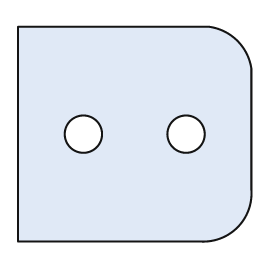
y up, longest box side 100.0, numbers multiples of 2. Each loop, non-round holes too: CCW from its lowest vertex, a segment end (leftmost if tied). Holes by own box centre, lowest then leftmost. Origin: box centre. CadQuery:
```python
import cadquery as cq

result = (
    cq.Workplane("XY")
    .moveTo(-50.0, -46.0)
    .lineTo(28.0, -46.0)
    .threePointArc((44.0, -40.0), (50.0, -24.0))
    .lineTo(50.0, 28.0)
    .threePointArc((44.0, 40.0), (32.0, 46.0))
    .lineTo(-50.0, 46.0)
    .close()
    .moveTo(-22.0, 0.0)
    .circle(8.0)
    .moveTo(22.0, 0.0)
    .circle(8.0)
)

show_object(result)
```